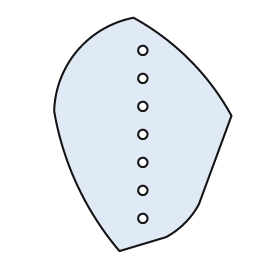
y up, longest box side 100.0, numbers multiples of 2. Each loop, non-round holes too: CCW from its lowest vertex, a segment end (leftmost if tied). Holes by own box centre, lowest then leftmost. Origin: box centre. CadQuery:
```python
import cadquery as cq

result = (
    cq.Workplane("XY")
    .moveTo(-10.0, -50.0)
    .lineTo(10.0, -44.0)
    .threePointArc((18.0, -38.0), (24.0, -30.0))
    .lineTo(38.0, 8.0)
    .threePointArc((20.0, 32.0), (-4.0, 50.0))
    .threePointArc((-28.0, 36.0), (-38.0, 10.0))
    .threePointArc((-28.0, -22.0), (-10.0, -50.0))
    .close()
    .moveTo(0.0, -36.0)
    .circle(2.0)
    .moveTo(0.0, -24.0)
    .circle(2.0)
    .moveTo(0.0, -12.0)
    .circle(2.0)
    .moveTo(0.0, 0.0)
    .circle(2.0)
    .moveTo(0.0, 12.0)
    .circle(2.0)
    .moveTo(0.0, 24.0)
    .circle(2.0)
    .moveTo(0.0, 36.0)
    .circle(2.0)
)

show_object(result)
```